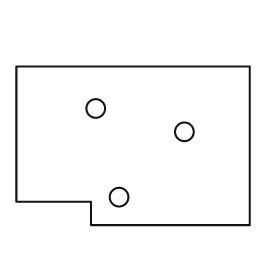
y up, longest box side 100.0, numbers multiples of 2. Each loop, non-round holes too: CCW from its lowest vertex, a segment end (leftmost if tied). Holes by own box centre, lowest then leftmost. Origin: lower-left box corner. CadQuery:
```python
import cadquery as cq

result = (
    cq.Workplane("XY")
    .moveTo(32.0, 0.0)
    .lineTo(100.0, 0.0)
    .lineTo(100.0, 68.0)
    .lineTo(0.0, 68.0)
    .lineTo(0.0, 10.0)
    .lineTo(32.0, 10.0)
    .close()
    .moveTo(44.0, 12.0)
    .circle(4.0)
    .moveTo(72.0, 40.0)
    .circle(4.0)
    .moveTo(34.0, 50.0)
    .circle(4.0)
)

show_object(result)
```